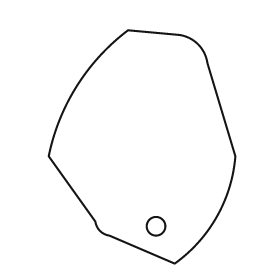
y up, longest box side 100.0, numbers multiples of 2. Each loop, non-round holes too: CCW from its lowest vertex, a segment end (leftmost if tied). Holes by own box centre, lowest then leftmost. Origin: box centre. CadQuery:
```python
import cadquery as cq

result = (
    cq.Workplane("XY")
    .moveTo(14.0, -50.0)
    .threePointArc((32.0, -30.0), (40.0, -4.0))
    .lineTo(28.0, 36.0)
    .threePointArc((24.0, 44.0), (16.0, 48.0))
    .lineTo(-6.0, 50.0)
    .threePointArc((-28.0, 26.0), (-40.0, -4.0))
    .lineTo(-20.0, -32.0)
    .threePointArc((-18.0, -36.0), (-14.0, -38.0))
    .close()
    .moveTo(6.0, -34.0)
    .circle(4.0)
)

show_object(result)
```